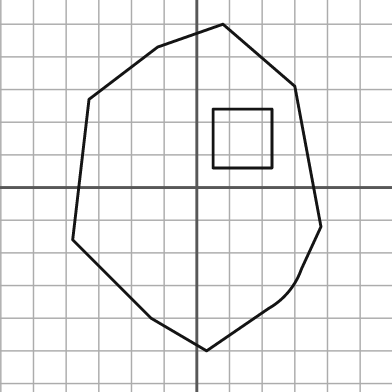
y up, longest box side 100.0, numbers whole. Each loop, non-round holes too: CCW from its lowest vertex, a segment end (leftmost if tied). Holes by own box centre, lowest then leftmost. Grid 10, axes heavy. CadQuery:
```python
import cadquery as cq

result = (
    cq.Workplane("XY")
    .moveTo(3.0, -50.0)
    .lineTo(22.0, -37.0)
    .threePointArc((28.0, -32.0), (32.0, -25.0))
    .lineTo(38.0, -12.0)
    .lineTo(30.0, 31.0)
    .lineTo(8.0, 50.0)
    .lineTo(-12.0, 43.0)
    .lineTo(-33.0, 27.0)
    .lineTo(-38.0, -16.0)
    .lineTo(-14.0, -40.0)
    .close()
    .moveTo(5.0, 6.0)
    .lineTo(23.0, 6.0)
    .lineTo(23.0, 24.0)
    .lineTo(5.0, 24.0)
    .close()
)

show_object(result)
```